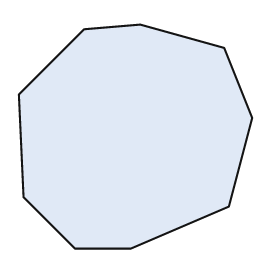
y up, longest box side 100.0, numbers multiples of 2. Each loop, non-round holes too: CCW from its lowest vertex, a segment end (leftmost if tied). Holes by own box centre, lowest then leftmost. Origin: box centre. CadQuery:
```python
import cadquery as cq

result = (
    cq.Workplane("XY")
    .moveTo(-26.0, -48.0)
    .lineTo(-2.0, -48.0)
    .lineTo(40.0, -30.0)
    .lineTo(50.0, 8.0)
    .lineTo(38.0, 38.0)
    .lineTo(2.0, 48.0)
    .lineTo(-22.0, 46.0)
    .lineTo(-50.0, 18.0)
    .lineTo(-48.0, -26.0)
    .close()
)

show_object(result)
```